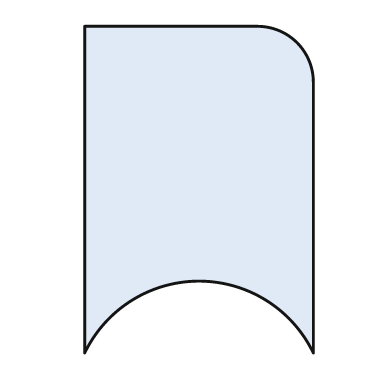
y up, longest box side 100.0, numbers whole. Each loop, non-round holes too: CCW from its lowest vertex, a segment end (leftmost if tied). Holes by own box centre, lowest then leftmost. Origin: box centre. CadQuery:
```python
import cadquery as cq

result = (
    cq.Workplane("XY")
    .moveTo(-35.0, -50.0)
    .threePointArc((0.0, -28.0), (35.0, -50.0))
    .lineTo(35.0, 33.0)
    .threePointArc((30.0, 45.0), (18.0, 50.0))
    .lineTo(-35.0, 50.0)
    .close()
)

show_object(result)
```